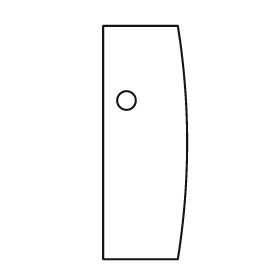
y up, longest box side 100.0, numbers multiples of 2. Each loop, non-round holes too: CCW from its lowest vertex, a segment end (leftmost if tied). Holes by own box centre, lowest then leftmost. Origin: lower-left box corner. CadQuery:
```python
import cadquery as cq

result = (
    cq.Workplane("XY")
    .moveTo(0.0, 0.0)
    .lineTo(32.0, 0.0)
    .threePointArc((36.0, 50.0), (32.0, 100.0))
    .lineTo(0.0, 100.0)
    .close()
    .moveTo(10.0, 68.0)
    .circle(4.0)
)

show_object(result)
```